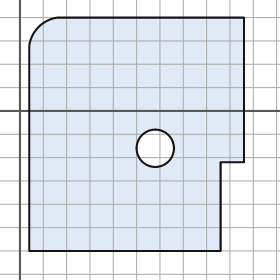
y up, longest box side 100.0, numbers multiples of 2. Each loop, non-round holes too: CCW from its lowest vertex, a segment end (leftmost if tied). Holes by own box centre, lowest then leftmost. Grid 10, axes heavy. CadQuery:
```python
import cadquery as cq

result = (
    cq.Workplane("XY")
    .moveTo(4.0, -60.0)
    .lineTo(86.0, -60.0)
    .lineTo(86.0, -22.0)
    .lineTo(96.0, -22.0)
    .lineTo(96.0, 40.0)
    .lineTo(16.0, 40.0)
    .threePointArc((8.0, 36.0), (4.0, 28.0))
    .close()
    .moveTo(58.0, -16.0)
    .circle(8.0)
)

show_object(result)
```